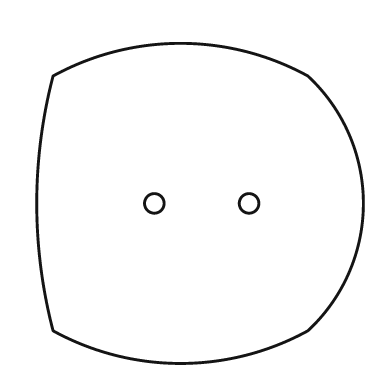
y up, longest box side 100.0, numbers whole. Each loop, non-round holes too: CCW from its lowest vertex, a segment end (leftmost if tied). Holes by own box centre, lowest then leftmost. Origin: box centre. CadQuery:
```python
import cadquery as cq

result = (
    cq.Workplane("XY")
    .moveTo(-45.0, -39.0)
    .threePointArc((-6.0, -49.0), (33.0, -39.0))
    .threePointArc((50.0, 0.0), (33.0, 39.0))
    .threePointArc((-6.0, 49.0), (-45.0, 39.0))
    .threePointArc((-50.0, 0.0), (-45.0, -39.0))
    .close()
    .moveTo(-14.0, 0.0)
    .circle(3.0)
    .moveTo(15.0, 0.0)
    .circle(3.0)
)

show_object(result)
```